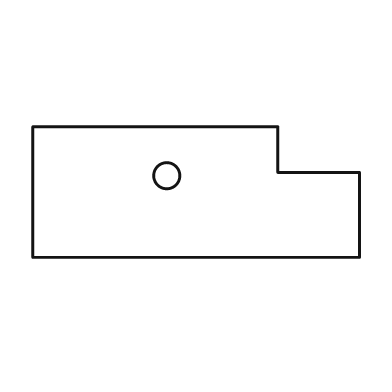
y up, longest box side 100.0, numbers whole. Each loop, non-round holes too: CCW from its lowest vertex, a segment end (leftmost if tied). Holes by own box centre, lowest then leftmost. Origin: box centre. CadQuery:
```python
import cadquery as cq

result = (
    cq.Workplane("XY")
    .moveTo(-50.0, -20.0)
    .lineTo(50.0, -20.0)
    .lineTo(50.0, 6.0)
    .lineTo(25.0, 6.0)
    .lineTo(25.0, 20.0)
    .lineTo(-50.0, 20.0)
    .close()
    .moveTo(-9.0, 5.0)
    .circle(4.0)
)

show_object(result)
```